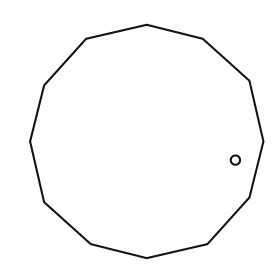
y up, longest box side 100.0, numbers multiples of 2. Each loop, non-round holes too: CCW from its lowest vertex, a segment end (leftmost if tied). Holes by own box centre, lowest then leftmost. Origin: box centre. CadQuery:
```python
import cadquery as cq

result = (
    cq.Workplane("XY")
    .moveTo(0.0, -50.0)
    .lineTo(26.0, -44.0)
    .lineTo(44.0, -24.0)
    .lineTo(50.0, 0.0)
    .lineTo(44.0, 26.0)
    .lineTo(24.0, 44.0)
    .lineTo(0.0, 50.0)
    .lineTo(-26.0, 44.0)
    .lineTo(-44.0, 24.0)
    .lineTo(-50.0, 0.0)
    .lineTo(-44.0, -26.0)
    .lineTo(-24.0, -44.0)
    .close()
    .moveTo(38.0, -8.0)
    .circle(2.0)
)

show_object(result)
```